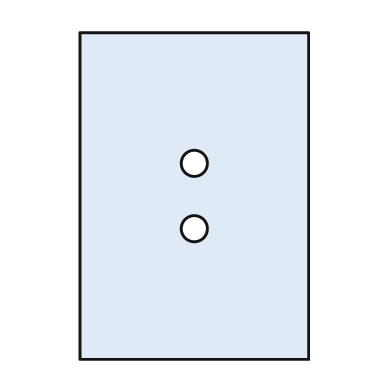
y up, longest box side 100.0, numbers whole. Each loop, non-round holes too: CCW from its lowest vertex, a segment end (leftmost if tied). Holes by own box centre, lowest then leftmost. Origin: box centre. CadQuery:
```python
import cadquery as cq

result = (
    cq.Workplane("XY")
    .moveTo(-35.0, -50.0)
    .lineTo(35.0, -50.0)
    .lineTo(35.0, 50.0)
    .lineTo(-35.0, 50.0)
    .close()
    .moveTo(0.0, -10.0)
    .circle(4.0)
    .moveTo(0.0, 10.0)
    .circle(4.0)
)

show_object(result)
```